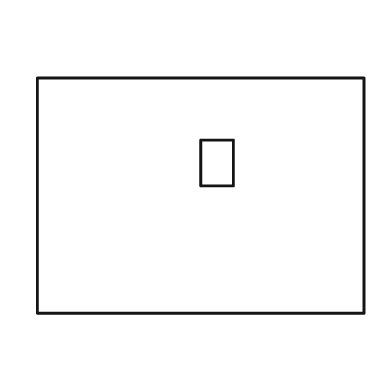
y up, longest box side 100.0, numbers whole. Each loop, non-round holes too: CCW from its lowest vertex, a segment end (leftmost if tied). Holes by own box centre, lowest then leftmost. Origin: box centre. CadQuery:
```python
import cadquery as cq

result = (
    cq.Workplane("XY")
    .moveTo(-50.0, -36.0)
    .lineTo(50.0, -36.0)
    .lineTo(50.0, 36.0)
    .lineTo(-50.0, 36.0)
    .close()
    .moveTo(0.0, 3.0)
    .lineTo(10.0, 3.0)
    .lineTo(10.0, 17.0)
    .lineTo(0.0, 17.0)
    .close()
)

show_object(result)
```